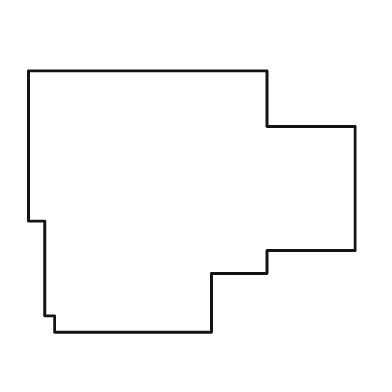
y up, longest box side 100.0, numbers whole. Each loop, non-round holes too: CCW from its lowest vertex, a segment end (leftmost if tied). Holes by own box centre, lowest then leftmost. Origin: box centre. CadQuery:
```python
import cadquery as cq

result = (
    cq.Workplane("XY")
    .moveTo(-42.0, -40.0)
    .lineTo(6.0, -40.0)
    .lineTo(6.0, -22.0)
    .lineTo(23.0, -22.0)
    .lineTo(23.0, -15.0)
    .lineTo(50.0, -15.0)
    .lineTo(50.0, 23.0)
    .lineTo(23.0, 23.0)
    .lineTo(23.0, 40.0)
    .lineTo(-50.0, 40.0)
    .lineTo(-50.0, -6.0)
    .lineTo(-45.0, -6.0)
    .lineTo(-45.0, -35.0)
    .lineTo(-42.0, -35.0)
    .close()
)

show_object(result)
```